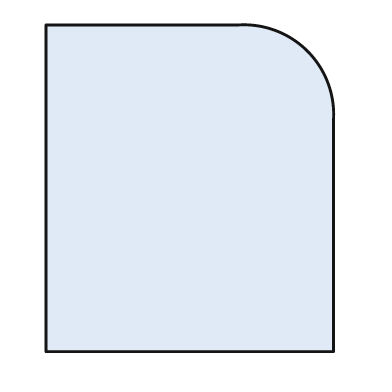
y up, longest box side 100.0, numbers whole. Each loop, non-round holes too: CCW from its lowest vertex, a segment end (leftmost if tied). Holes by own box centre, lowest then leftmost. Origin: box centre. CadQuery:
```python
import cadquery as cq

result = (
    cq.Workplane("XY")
    .moveTo(-44.0, -50.0)
    .lineTo(44.0, -50.0)
    .lineTo(44.0, 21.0)
    .threePointArc((36.0, 42.0), (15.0, 50.0))
    .lineTo(-44.0, 50.0)
    .close()
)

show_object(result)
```